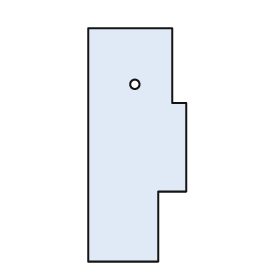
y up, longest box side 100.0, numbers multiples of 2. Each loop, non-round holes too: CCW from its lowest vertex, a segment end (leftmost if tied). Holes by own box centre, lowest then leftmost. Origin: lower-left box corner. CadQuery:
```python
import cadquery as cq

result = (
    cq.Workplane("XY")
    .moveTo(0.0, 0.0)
    .lineTo(30.0, 0.0)
    .lineTo(30.0, 30.0)
    .lineTo(42.0, 30.0)
    .lineTo(42.0, 68.0)
    .lineTo(36.0, 68.0)
    .lineTo(36.0, 100.0)
    .lineTo(0.0, 100.0)
    .close()
    .moveTo(20.0, 76.0)
    .circle(2.0)
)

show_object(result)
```